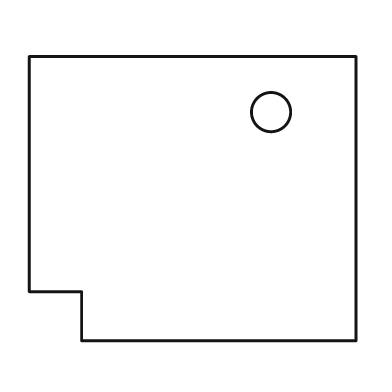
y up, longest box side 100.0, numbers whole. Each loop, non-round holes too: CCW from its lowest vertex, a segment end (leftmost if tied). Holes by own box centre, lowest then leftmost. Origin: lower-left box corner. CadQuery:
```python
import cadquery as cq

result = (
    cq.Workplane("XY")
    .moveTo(16.0, 0.0)
    .lineTo(100.0, 0.0)
    .lineTo(100.0, 87.0)
    .lineTo(0.0, 87.0)
    .lineTo(0.0, 15.0)
    .lineTo(16.0, 15.0)
    .close()
    .moveTo(74.0, 70.0)
    .circle(6.0)
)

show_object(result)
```